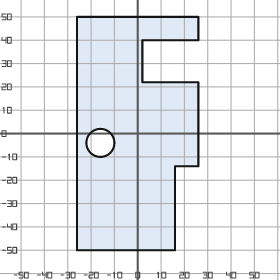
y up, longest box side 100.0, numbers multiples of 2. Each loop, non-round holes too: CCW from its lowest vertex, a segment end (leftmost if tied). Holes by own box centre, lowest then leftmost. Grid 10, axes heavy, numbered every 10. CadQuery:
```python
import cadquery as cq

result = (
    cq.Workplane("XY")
    .moveTo(-26.0, -50.0)
    .lineTo(16.0, -50.0)
    .lineTo(16.0, -14.0)
    .lineTo(26.0, -14.0)
    .lineTo(26.0, 22.0)
    .lineTo(2.0, 22.0)
    .lineTo(2.0, 40.0)
    .lineTo(26.0, 40.0)
    .lineTo(26.0, 50.0)
    .lineTo(-26.0, 50.0)
    .close()
    .moveTo(-16.0, -4.0)
    .circle(6.0)
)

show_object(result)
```